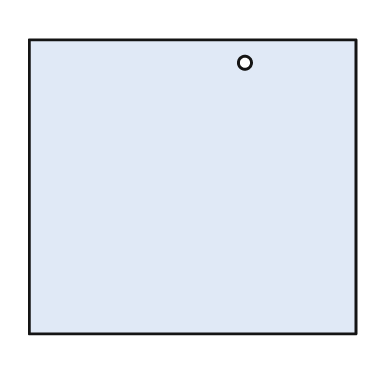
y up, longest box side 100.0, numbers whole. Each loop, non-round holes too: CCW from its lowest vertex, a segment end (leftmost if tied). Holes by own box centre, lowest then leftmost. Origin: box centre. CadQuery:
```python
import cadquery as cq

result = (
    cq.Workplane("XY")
    .moveTo(-50.0, -45.0)
    .lineTo(50.0, -45.0)
    .lineTo(50.0, 45.0)
    .lineTo(-50.0, 45.0)
    .close()
    .moveTo(16.0, 38.0)
    .circle(2.0)
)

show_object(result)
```